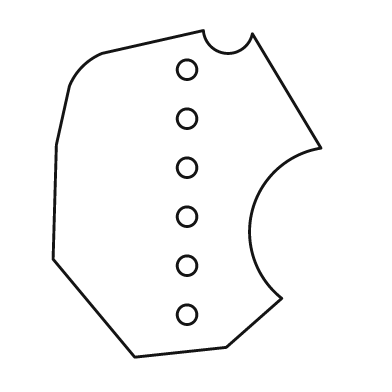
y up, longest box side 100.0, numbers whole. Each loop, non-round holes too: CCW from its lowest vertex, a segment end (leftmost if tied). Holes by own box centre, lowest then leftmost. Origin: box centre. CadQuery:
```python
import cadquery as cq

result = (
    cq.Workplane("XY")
    .moveTo(-16.0, -50.0)
    .lineTo(12.0, -47.0)
    .lineTo(29.0, -32.0)
    .threePointArc((20.0, -5.0), (41.0, 14.0))
    .lineTo(20.0, 49.0)
    .threePointArc((12.0, 43.0), (5.0, 50.0))
    .lineTo(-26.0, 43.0)
    .threePointArc((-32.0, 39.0), (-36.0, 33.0))
    .lineTo(-40.0, 15.0)
    .lineTo(-41.0, -20.0)
    .close()
    .moveTo(0.0, -37.0)
    .circle(3.0)
    .moveTo(0.0, -22.0)
    .circle(3.0)
    .moveTo(0.0, -7.0)
    .circle(3.0)
    .moveTo(0.0, 8.0)
    .circle(3.0)
    .moveTo(0.0, 23.0)
    .circle(3.0)
    .moveTo(0.0, 38.0)
    .circle(3.0)
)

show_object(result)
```